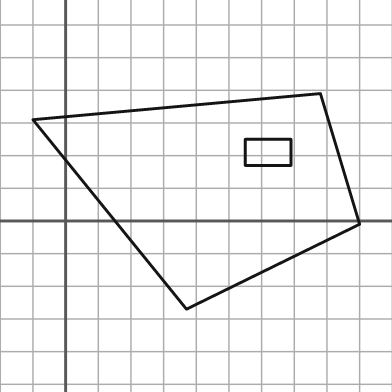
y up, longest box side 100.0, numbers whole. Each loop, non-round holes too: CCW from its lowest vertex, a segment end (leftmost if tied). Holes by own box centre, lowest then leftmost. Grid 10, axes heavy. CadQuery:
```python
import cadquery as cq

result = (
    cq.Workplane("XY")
    .moveTo(37.0, -27.0)
    .lineTo(90.0, -1.0)
    .lineTo(78.0, 39.0)
    .lineTo(-10.0, 31.0)
    .close()
    .moveTo(55.0, 17.0)
    .lineTo(69.0, 17.0)
    .lineTo(69.0, 25.0)
    .lineTo(55.0, 25.0)
    .close()
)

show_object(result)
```